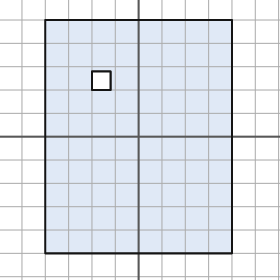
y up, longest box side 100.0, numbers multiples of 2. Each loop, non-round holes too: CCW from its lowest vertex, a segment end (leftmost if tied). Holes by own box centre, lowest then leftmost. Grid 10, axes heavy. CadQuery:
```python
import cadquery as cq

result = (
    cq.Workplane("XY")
    .moveTo(-40.0, -50.0)
    .lineTo(40.0, -50.0)
    .lineTo(40.0, 50.0)
    .lineTo(-40.0, 50.0)
    .close()
    .moveTo(-20.0, 20.0)
    .lineTo(-12.0, 20.0)
    .lineTo(-12.0, 28.0)
    .lineTo(-20.0, 28.0)
    .close()
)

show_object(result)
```